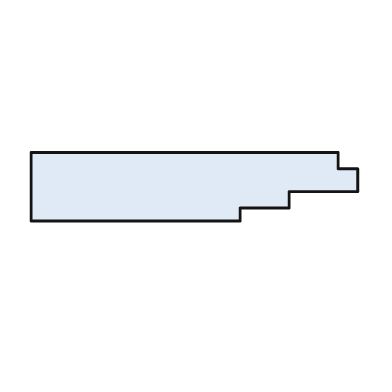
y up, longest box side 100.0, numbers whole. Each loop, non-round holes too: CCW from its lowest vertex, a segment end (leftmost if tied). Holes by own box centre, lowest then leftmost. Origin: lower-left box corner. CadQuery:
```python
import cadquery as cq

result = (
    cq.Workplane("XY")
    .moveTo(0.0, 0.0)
    .lineTo(64.0, 0.0)
    .lineTo(64.0, 4.0)
    .lineTo(79.0, 4.0)
    .lineTo(79.0, 9.0)
    .lineTo(100.0, 9.0)
    .lineTo(100.0, 16.0)
    .lineTo(94.0, 16.0)
    .lineTo(94.0, 21.0)
    .lineTo(0.0, 21.0)
    .close()
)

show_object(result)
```